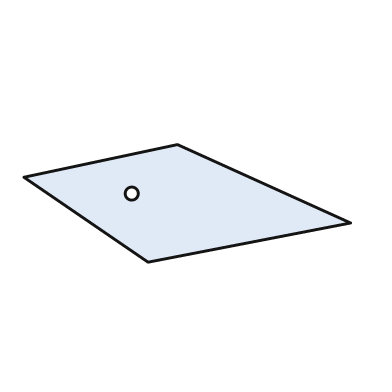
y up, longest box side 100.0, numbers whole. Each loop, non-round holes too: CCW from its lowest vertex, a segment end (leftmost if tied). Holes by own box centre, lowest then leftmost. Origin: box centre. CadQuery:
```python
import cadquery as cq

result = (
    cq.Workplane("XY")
    .moveTo(-12.0, -18.0)
    .lineTo(50.0, -6.0)
    .lineTo(-3.0, 18.0)
    .lineTo(-50.0, 8.0)
    .close()
    .moveTo(-17.0, 3.0)
    .circle(2.0)
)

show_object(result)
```